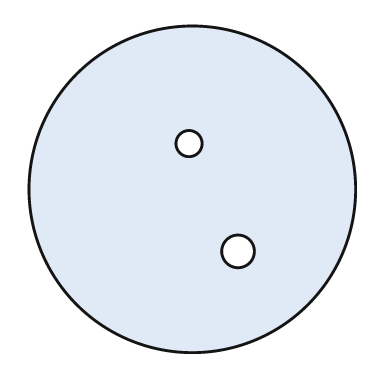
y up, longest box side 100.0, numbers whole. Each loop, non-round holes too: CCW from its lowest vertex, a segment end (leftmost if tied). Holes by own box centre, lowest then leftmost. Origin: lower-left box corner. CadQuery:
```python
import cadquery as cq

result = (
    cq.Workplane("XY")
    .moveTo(50.0, 50.0)
    .circle(50.0)
    .moveTo(64.0, 31.0)
    .circle(5.0)
    .moveTo(49.0, 64.0)
    .circle(4.0)
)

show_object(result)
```